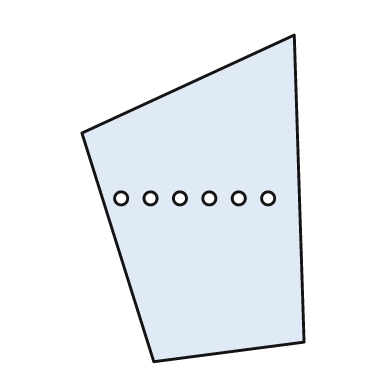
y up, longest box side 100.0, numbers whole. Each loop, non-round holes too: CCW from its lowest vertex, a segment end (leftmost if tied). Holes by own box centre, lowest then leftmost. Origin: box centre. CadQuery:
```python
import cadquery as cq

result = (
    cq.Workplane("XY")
    .moveTo(-12.0, -50.0)
    .lineTo(34.0, -44.0)
    .lineTo(31.0, 50.0)
    .lineTo(-34.0, 20.0)
    .close()
    .moveTo(-22.0, 0.0)
    .circle(2.0)
    .moveTo(-13.0, 0.0)
    .circle(2.0)
    .moveTo(-4.0, 0.0)
    .circle(2.0)
    .moveTo(5.0, 0.0)
    .circle(2.0)
    .moveTo(14.0, 0.0)
    .circle(2.0)
    .moveTo(23.0, 0.0)
    .circle(2.0)
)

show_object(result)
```